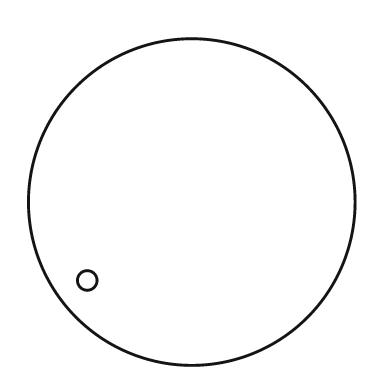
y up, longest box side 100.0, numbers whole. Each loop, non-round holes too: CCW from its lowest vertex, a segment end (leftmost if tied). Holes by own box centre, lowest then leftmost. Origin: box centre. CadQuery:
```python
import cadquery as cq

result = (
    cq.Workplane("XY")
    .moveTo(0.0, 0.0)
    .circle(50.0)
    .moveTo(-32.0, -24.0)
    .circle(3.0)
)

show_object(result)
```